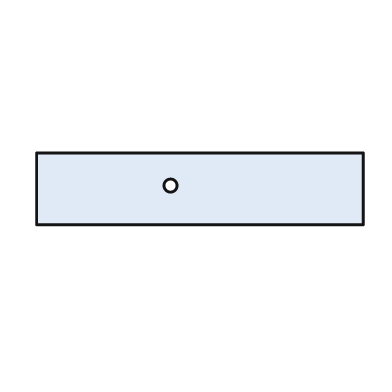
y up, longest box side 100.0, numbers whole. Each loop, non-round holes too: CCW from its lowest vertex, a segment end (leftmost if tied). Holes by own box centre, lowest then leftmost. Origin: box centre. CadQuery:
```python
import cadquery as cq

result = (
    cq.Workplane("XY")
    .moveTo(-50.0, -11.0)
    .lineTo(50.0, -11.0)
    .lineTo(50.0, 11.0)
    .lineTo(-50.0, 11.0)
    .close()
    .moveTo(-9.0, 1.0)
    .circle(2.0)
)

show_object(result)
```